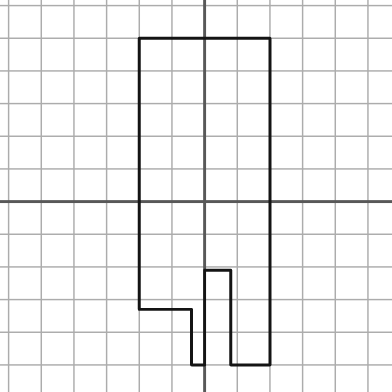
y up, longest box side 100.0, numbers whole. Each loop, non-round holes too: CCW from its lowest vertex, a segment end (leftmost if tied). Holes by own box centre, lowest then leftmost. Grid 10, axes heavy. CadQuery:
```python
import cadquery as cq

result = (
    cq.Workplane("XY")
    .moveTo(-4.0, -50.0)
    .lineTo(0.0, -50.0)
    .lineTo(0.0, -21.0)
    .lineTo(8.0, -21.0)
    .lineTo(8.0, -50.0)
    .lineTo(20.0, -50.0)
    .lineTo(20.0, 50.0)
    .lineTo(-20.0, 50.0)
    .lineTo(-20.0, -33.0)
    .lineTo(-4.0, -33.0)
    .close()
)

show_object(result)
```